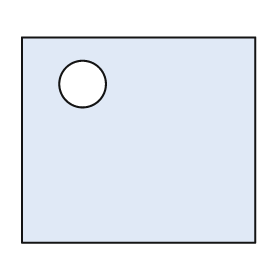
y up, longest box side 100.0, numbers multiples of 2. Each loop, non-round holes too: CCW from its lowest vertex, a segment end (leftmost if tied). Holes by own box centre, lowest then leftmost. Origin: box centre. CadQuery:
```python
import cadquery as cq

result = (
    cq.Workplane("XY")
    .moveTo(-50.0, -44.0)
    .lineTo(50.0, -44.0)
    .lineTo(50.0, 44.0)
    .lineTo(-50.0, 44.0)
    .close()
    .moveTo(-24.0, 24.0)
    .circle(10.0)
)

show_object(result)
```